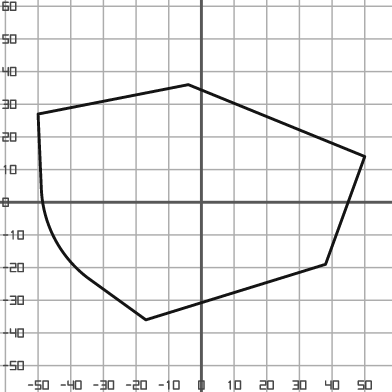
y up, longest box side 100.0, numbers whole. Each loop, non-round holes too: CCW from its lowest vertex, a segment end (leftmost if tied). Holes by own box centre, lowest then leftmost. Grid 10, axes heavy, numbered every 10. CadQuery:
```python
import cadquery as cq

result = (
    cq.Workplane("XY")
    .moveTo(-17.0, -36.0)
    .lineTo(38.0, -19.0)
    .lineTo(50.0, 14.0)
    .lineTo(-4.0, 36.0)
    .lineTo(-50.0, 27.0)
    .lineTo(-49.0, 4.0)
    .threePointArc((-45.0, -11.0), (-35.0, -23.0))
    .close()
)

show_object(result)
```